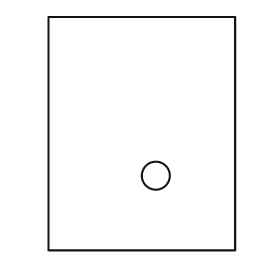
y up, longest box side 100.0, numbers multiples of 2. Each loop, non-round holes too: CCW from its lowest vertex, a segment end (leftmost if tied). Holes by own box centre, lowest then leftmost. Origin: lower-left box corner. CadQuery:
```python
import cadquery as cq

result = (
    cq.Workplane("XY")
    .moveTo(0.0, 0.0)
    .lineTo(80.0, 0.0)
    .lineTo(80.0, 100.0)
    .lineTo(0.0, 100.0)
    .close()
    .moveTo(46.0, 32.0)
    .circle(6.0)
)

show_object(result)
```